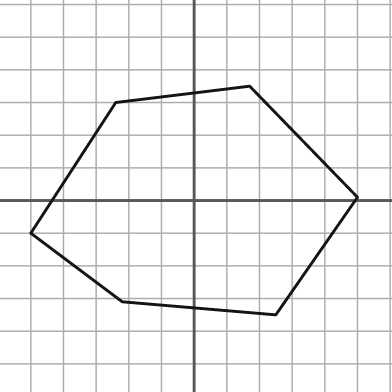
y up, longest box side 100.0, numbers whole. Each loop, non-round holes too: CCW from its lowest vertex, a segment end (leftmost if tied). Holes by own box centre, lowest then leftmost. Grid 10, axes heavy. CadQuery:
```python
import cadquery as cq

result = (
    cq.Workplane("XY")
    .moveTo(25.0, -35.0)
    .lineTo(50.0, 1.0)
    .lineTo(17.0, 35.0)
    .lineTo(-24.0, 30.0)
    .lineTo(-50.0, -10.0)
    .lineTo(-22.0, -31.0)
    .close()
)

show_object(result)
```